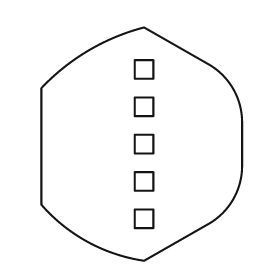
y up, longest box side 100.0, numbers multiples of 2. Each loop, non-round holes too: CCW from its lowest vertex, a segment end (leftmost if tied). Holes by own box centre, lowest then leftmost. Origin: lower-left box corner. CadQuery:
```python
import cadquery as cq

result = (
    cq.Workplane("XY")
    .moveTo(44.0, 0.0)
    .lineTo(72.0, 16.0)
    .threePointArc((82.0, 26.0), (86.0, 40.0))
    .lineTo(86.0, 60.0)
    .threePointArc((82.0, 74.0), (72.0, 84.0))
    .lineTo(44.0, 100.0)
    .threePointArc((20.0, 90.0), (0.0, 74.0))
    .lineTo(0.0, 24.0)
    .threePointArc((20.0, 8.0), (44.0, 0.0))
    .close()
    .moveTo(40.0, 14.0)
    .lineTo(48.0, 14.0)
    .lineTo(48.0, 22.0)
    .lineTo(40.0, 22.0)
    .close()
    .moveTo(40.0, 30.0)
    .lineTo(48.0, 30.0)
    .lineTo(48.0, 38.0)
    .lineTo(40.0, 38.0)
    .close()
    .moveTo(40.0, 46.0)
    .lineTo(48.0, 46.0)
    .lineTo(48.0, 54.0)
    .lineTo(40.0, 54.0)
    .close()
    .moveTo(40.0, 62.0)
    .lineTo(48.0, 62.0)
    .lineTo(48.0, 70.0)
    .lineTo(40.0, 70.0)
    .close()
    .moveTo(40.0, 78.0)
    .lineTo(48.0, 78.0)
    .lineTo(48.0, 86.0)
    .lineTo(40.0, 86.0)
    .close()
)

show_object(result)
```